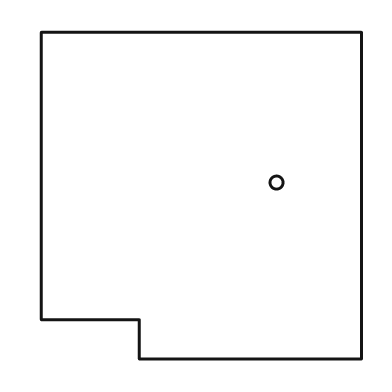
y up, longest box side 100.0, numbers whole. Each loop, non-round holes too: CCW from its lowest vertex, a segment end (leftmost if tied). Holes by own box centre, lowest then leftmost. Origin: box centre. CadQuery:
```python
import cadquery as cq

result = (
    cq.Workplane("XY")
    .moveTo(-19.0, -50.0)
    .lineTo(49.0, -50.0)
    .lineTo(49.0, 50.0)
    .lineTo(-49.0, 50.0)
    .lineTo(-49.0, -38.0)
    .lineTo(-19.0, -38.0)
    .close()
    .moveTo(23.0, 4.0)
    .circle(2.0)
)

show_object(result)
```